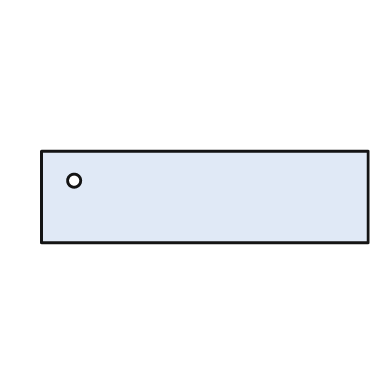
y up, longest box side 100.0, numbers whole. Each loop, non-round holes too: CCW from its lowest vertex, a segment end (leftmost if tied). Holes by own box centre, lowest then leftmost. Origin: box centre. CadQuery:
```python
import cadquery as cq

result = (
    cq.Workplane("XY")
    .moveTo(-50.0, -14.0)
    .lineTo(50.0, -14.0)
    .lineTo(50.0, 14.0)
    .lineTo(-50.0, 14.0)
    .close()
    .moveTo(-40.0, 5.0)
    .circle(2.0)
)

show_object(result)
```